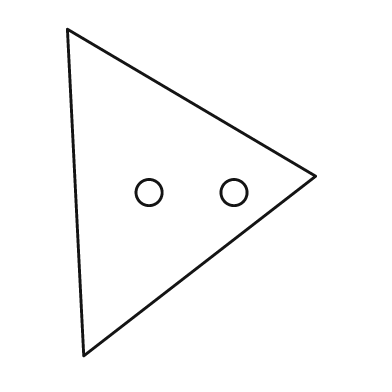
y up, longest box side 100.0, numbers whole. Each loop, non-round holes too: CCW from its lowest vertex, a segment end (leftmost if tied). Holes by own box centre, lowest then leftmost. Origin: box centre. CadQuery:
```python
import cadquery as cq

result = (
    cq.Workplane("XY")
    .moveTo(-33.0, -50.0)
    .lineTo(38.0, 5.0)
    .lineTo(-38.0, 50.0)
    .close()
    .moveTo(-13.0, 0.0)
    .circle(4.0)
    .moveTo(13.0, 0.0)
    .circle(4.0)
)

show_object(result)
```